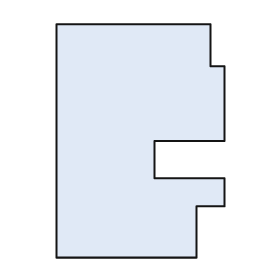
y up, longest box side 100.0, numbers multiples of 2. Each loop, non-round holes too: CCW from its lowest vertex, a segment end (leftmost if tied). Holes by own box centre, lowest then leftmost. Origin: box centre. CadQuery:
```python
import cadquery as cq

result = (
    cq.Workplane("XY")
    .moveTo(-36.0, -50.0)
    .lineTo(24.0, -50.0)
    .lineTo(24.0, -28.0)
    .lineTo(36.0, -28.0)
    .lineTo(36.0, -16.0)
    .lineTo(6.0, -16.0)
    .lineTo(6.0, 0.0)
    .lineTo(36.0, 0.0)
    .lineTo(36.0, 32.0)
    .lineTo(30.0, 32.0)
    .lineTo(30.0, 50.0)
    .lineTo(-36.0, 50.0)
    .close()
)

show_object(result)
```